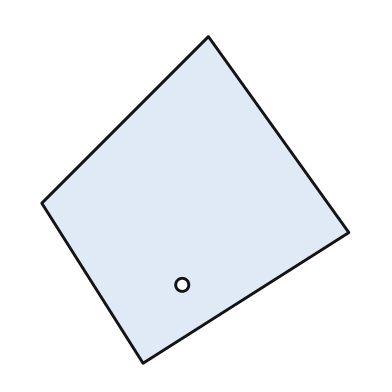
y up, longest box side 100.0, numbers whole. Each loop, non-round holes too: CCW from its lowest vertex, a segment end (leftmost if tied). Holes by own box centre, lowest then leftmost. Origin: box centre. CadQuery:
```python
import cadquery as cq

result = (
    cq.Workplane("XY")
    .moveTo(-16.0, -50.0)
    .lineTo(47.0, -10.0)
    .lineTo(4.0, 50.0)
    .lineTo(-47.0, -1.0)
    .close()
    .moveTo(-4.0, -26.0)
    .circle(2.0)
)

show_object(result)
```